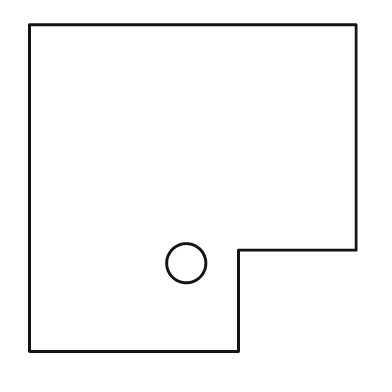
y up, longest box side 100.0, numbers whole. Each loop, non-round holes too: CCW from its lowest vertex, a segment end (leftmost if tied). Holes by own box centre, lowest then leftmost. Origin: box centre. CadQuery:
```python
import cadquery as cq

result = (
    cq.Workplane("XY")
    .moveTo(-50.0, -50.0)
    .lineTo(14.0, -50.0)
    .lineTo(14.0, -19.0)
    .lineTo(50.0, -19.0)
    .lineTo(50.0, 50.0)
    .lineTo(-50.0, 50.0)
    .close()
    .moveTo(-2.0, -23.0)
    .circle(6.0)
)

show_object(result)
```